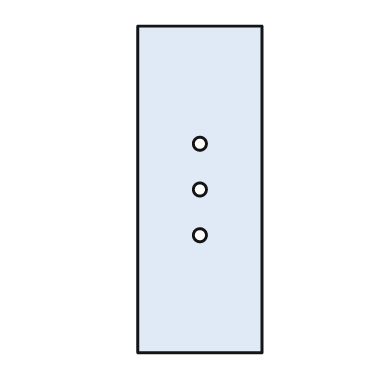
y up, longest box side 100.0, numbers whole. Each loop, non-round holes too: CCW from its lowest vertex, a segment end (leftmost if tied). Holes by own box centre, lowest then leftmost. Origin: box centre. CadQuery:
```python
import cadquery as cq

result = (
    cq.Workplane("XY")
    .moveTo(-19.0, -50.0)
    .lineTo(19.0, -50.0)
    .lineTo(19.0, 50.0)
    .lineTo(-19.0, 50.0)
    .close()
    .moveTo(0.0, -14.0)
    .circle(2.0)
    .moveTo(0.0, 0.0)
    .circle(2.0)
    .moveTo(0.0, 14.0)
    .circle(2.0)
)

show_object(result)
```